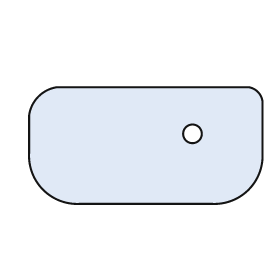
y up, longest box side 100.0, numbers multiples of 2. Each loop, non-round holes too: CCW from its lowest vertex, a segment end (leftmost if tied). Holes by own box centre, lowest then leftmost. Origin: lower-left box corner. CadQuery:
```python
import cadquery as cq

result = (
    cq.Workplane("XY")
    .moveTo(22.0, 0.0)
    .lineTo(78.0, 0.0)
    .threePointArc((94.0, 6.0), (100.0, 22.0))
    .lineTo(100.0, 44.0)
    .threePointArc((98.0, 48.0), (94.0, 50.0))
    .lineTo(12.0, 50.0)
    .threePointArc((4.0, 46.0), (0.0, 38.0))
    .lineTo(0.0, 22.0)
    .threePointArc((6.0, 6.0), (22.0, 0.0))
    .close()
    .moveTo(70.0, 30.0)
    .circle(4.0)
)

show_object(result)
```